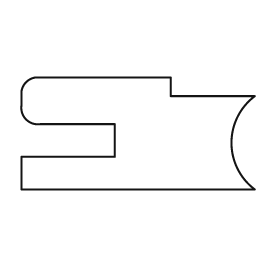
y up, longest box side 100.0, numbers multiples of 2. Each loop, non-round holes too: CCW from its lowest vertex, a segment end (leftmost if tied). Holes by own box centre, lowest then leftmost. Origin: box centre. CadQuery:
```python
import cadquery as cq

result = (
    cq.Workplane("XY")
    .moveTo(-50.0, -24.0)
    .lineTo(50.0, -24.0)
    .threePointArc((40.0, -4.0), (50.0, 16.0))
    .lineTo(14.0, 16.0)
    .lineTo(14.0, 24.0)
    .lineTo(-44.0, 24.0)
    .threePointArc((-48.0, 22.0), (-50.0, 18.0))
    .lineTo(-50.0, 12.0)
    .threePointArc((-48.0, 6.0), (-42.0, 4.0))
    .lineTo(-10.0, 4.0)
    .lineTo(-10.0, -10.0)
    .lineTo(-50.0, -10.0)
    .close()
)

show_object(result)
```